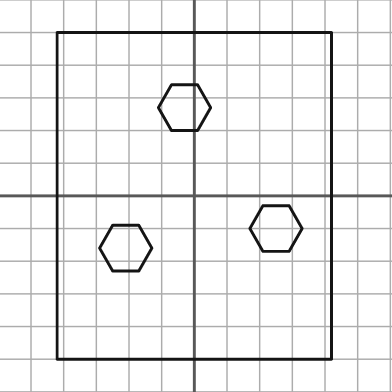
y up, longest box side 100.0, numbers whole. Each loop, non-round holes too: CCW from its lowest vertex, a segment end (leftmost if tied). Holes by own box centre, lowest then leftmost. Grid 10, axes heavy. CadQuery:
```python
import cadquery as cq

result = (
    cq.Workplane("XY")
    .moveTo(-42.0, -50.0)
    .lineTo(42.0, -50.0)
    .lineTo(42.0, 50.0)
    .lineTo(-42.0, 50.0)
    .close()
    .moveTo(-25.0, -23.0)
    .lineTo(-17.0, -23.0)
    .lineTo(-13.0, -16.0)
    .lineTo(-17.0, -9.0)
    .lineTo(-25.0, -9.0)
    .lineTo(-29.0, -16.0)
    .close()
    .moveTo(21.0, -17.0)
    .lineTo(29.0, -17.0)
    .lineTo(33.0, -10.0)
    .lineTo(29.0, -3.0)
    .lineTo(21.0, -3.0)
    .lineTo(17.0, -10.0)
    .close()
    .moveTo(-7.0, 20.0)
    .lineTo(1.0, 20.0)
    .lineTo(5.0, 27.0)
    .lineTo(1.0, 34.0)
    .lineTo(-7.0, 34.0)
    .lineTo(-11.0, 27.0)
    .close()
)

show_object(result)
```